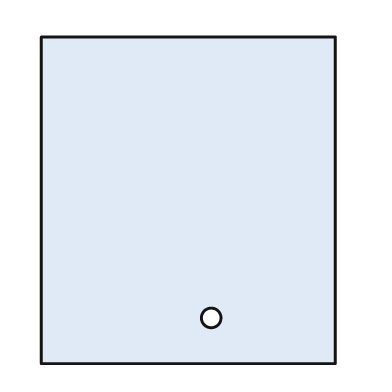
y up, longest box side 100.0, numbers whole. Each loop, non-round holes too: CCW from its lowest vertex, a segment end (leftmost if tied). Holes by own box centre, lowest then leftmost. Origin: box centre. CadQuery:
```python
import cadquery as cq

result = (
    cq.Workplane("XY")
    .moveTo(-45.0, -50.0)
    .lineTo(45.0, -50.0)
    .lineTo(45.0, 50.0)
    .lineTo(-45.0, 50.0)
    .close()
    .moveTo(7.0, -36.0)
    .circle(3.0)
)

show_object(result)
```